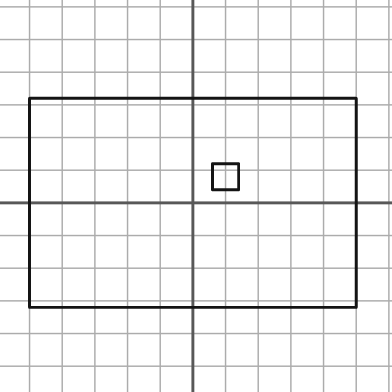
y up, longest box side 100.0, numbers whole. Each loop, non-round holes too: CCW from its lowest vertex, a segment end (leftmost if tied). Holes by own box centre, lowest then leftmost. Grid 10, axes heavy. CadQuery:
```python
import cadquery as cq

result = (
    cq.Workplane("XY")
    .moveTo(-50.0, -32.0)
    .lineTo(50.0, -32.0)
    .lineTo(50.0, 32.0)
    .lineTo(-50.0, 32.0)
    .close()
    .moveTo(6.0, 4.0)
    .lineTo(14.0, 4.0)
    .lineTo(14.0, 12.0)
    .lineTo(6.0, 12.0)
    .close()
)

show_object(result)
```